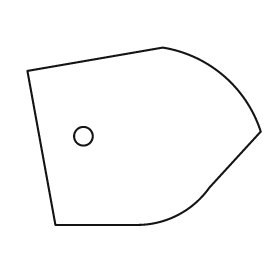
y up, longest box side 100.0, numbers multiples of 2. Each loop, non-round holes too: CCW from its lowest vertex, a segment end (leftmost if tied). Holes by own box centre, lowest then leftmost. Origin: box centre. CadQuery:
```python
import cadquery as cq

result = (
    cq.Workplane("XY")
    .moveTo(-38.0, -38.0)
    .lineTo(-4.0, -38.0)
    .threePointArc((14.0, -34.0), (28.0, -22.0))
    .lineTo(50.0, 2.0)
    .threePointArc((34.0, 26.0), (8.0, 38.0))
    .lineTo(-50.0, 28.0)
    .close()
    .moveTo(-26.0, 0.0)
    .circle(4.0)
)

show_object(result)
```